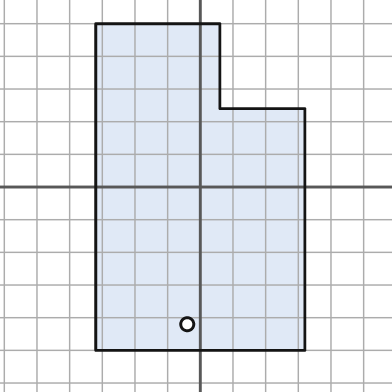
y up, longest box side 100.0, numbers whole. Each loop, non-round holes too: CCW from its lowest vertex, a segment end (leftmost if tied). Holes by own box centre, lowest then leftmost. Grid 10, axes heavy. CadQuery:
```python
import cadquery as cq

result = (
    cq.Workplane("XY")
    .moveTo(-32.0, -50.0)
    .lineTo(32.0, -50.0)
    .lineTo(32.0, 24.0)
    .lineTo(6.0, 24.0)
    .lineTo(6.0, 50.0)
    .lineTo(-32.0, 50.0)
    .close()
    .moveTo(-4.0, -42.0)
    .circle(2.0)
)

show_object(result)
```